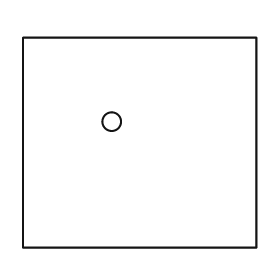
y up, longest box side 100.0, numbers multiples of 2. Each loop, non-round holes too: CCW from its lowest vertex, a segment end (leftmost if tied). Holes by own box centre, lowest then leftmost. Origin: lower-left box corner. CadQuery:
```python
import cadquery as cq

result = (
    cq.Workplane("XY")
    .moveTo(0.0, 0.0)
    .lineTo(100.0, 0.0)
    .lineTo(100.0, 90.0)
    .lineTo(0.0, 90.0)
    .close()
    .moveTo(38.0, 54.0)
    .circle(4.0)
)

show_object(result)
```